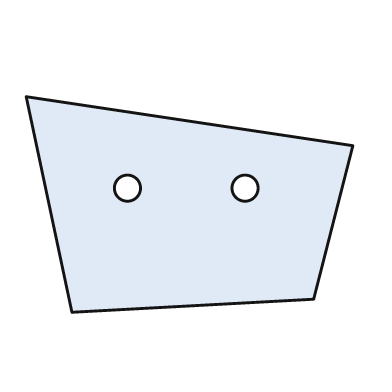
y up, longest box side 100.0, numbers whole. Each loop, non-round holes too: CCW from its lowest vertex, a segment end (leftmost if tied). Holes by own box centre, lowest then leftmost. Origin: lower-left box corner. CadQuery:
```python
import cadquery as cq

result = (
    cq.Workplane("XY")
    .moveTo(14.0, 0.0)
    .lineTo(88.0, 4.0)
    .lineTo(100.0, 51.0)
    .lineTo(0.0, 66.0)
    .close()
    .moveTo(31.0, 38.0)
    .circle(4.0)
    .moveTo(67.0, 38.0)
    .circle(4.0)
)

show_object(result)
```